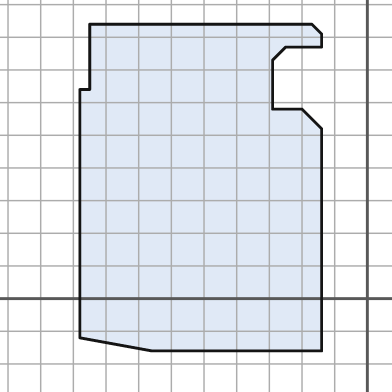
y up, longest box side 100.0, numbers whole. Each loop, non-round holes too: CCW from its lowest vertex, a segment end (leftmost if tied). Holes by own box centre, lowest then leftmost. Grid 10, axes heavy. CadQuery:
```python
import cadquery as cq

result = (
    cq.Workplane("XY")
    .moveTo(-66.0, -16.0)
    .lineTo(-14.0, -16.0)
    .lineTo(-14.0, 52.0)
    .lineTo(-20.0, 58.0)
    .lineTo(-29.0, 58.0)
    .lineTo(-29.0, 73.0)
    .lineTo(-25.0, 77.0)
    .lineTo(-14.0, 77.0)
    .lineTo(-14.0, 81.0)
    .lineTo(-17.0, 84.0)
    .lineTo(-85.0, 84.0)
    .lineTo(-85.0, 64.0)
    .lineTo(-88.0, 64.0)
    .lineTo(-88.0, -12.0)
    .close()
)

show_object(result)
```